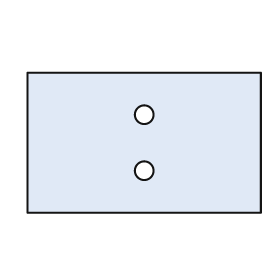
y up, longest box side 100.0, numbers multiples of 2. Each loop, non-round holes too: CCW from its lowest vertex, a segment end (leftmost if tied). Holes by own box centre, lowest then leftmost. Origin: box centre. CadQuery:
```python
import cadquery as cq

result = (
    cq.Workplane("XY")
    .moveTo(-50.0, -30.0)
    .lineTo(50.0, -30.0)
    .lineTo(50.0, 30.0)
    .lineTo(-50.0, 30.0)
    .close()
    .moveTo(0.0, -12.0)
    .circle(4.0)
    .moveTo(0.0, 12.0)
    .circle(4.0)
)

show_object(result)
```